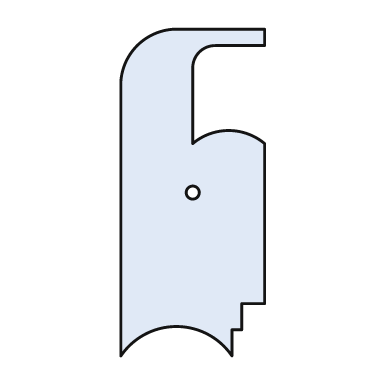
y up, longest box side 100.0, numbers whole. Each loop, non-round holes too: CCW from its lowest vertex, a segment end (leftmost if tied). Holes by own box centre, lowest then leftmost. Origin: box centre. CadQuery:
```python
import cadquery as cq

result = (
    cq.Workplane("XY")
    .moveTo(-22.0, -50.0)
    .threePointArc((-5.0, -41.0), (12.0, -50.0))
    .lineTo(12.0, -42.0)
    .lineTo(15.0, -42.0)
    .lineTo(15.0, -34.0)
    .lineTo(22.0, -34.0)
    .lineTo(22.0, 15.0)
    .threePointArc((11.0, 19.0), (0.0, 15.0))
    .lineTo(0.0, 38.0)
    .threePointArc((2.0, 43.0), (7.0, 45.0))
    .lineTo(22.0, 45.0)
    .lineTo(22.0, 50.0)
    .lineTo(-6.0, 50.0)
    .threePointArc((-17.0, 45.0), (-22.0, 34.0))
    .close()
    .moveTo(0.0, 0.0)
    .circle(2.0)
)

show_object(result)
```